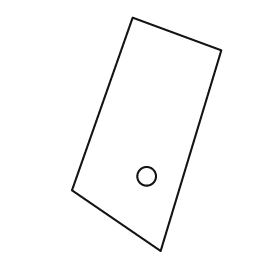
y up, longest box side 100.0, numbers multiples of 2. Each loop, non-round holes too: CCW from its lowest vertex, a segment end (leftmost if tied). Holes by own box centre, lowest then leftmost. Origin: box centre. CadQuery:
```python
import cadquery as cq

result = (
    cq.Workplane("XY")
    .moveTo(6.0, -50.0)
    .lineTo(32.0, 36.0)
    .lineTo(-6.0, 50.0)
    .lineTo(-32.0, -24.0)
    .close()
    .moveTo(0.0, -18.0)
    .circle(4.0)
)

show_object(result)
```